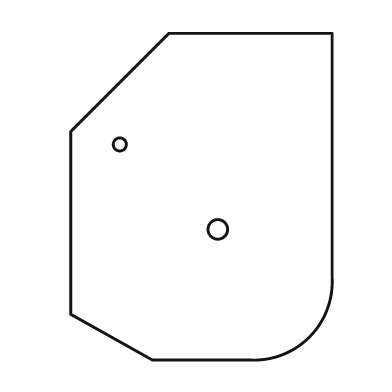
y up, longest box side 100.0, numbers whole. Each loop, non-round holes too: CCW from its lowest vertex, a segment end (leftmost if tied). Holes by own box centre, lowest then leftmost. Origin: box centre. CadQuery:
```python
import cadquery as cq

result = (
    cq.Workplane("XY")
    .moveTo(-15.0, -50.0)
    .lineTo(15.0, -50.0)
    .threePointArc((33.0, -43.0), (40.0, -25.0))
    .lineTo(40.0, 50.0)
    .lineTo(-10.0, 50.0)
    .lineTo(-40.0, 20.0)
    .lineTo(-40.0, -36.0)
    .close()
    .moveTo(5.0, -10.0)
    .circle(3.0)
    .moveTo(-25.0, 16.0)
    .circle(2.0)
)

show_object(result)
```